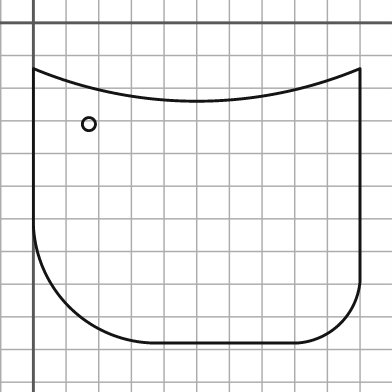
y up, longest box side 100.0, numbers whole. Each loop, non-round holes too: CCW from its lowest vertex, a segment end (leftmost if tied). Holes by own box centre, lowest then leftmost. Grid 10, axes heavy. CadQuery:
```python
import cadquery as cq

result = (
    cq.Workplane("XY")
    .moveTo(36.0, -98.0)
    .lineTo(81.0, -98.0)
    .threePointArc((94.0, -92.0), (100.0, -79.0))
    .lineTo(100.0, -14.0)
    .threePointArc((50.0, -24.0), (0.0, -14.0))
    .lineTo(0.0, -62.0)
    .threePointArc((11.0, -87.0), (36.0, -98.0))
    .close()
    .moveTo(17.0, -31.0)
    .circle(2.0)
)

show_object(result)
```